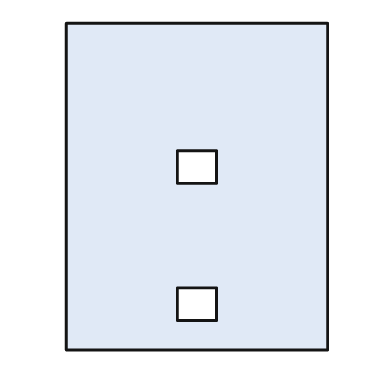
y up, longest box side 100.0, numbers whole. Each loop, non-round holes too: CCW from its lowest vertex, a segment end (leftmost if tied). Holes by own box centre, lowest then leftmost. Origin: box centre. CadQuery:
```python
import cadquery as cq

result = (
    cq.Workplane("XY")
    .moveTo(-40.0, -50.0)
    .lineTo(40.0, -50.0)
    .lineTo(40.0, 50.0)
    .lineTo(-40.0, 50.0)
    .close()
    .moveTo(-6.0, -41.0)
    .lineTo(6.0, -41.0)
    .lineTo(6.0, -31.0)
    .lineTo(-6.0, -31.0)
    .close()
    .moveTo(-6.0, 1.0)
    .lineTo(6.0, 1.0)
    .lineTo(6.0, 11.0)
    .lineTo(-6.0, 11.0)
    .close()
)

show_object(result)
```